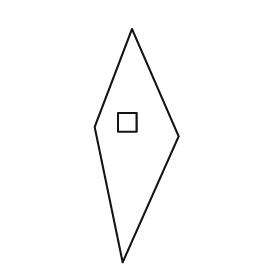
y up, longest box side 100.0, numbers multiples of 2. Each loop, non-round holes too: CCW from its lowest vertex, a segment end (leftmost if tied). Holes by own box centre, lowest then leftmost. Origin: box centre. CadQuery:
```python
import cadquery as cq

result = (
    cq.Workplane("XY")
    .moveTo(-6.0, -50.0)
    .lineTo(18.0, 4.0)
    .lineTo(-2.0, 50.0)
    .lineTo(-18.0, 8.0)
    .close()
    .moveTo(-8.0, 6.0)
    .lineTo(0.0, 6.0)
    .lineTo(0.0, 14.0)
    .lineTo(-8.0, 14.0)
    .close()
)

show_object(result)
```